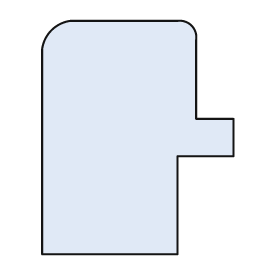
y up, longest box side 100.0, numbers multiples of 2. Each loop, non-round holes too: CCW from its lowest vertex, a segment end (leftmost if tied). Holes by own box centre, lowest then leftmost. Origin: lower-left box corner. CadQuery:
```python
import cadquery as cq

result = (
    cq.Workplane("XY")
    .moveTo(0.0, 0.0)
    .lineTo(58.0, 0.0)
    .lineTo(58.0, 42.0)
    .lineTo(82.0, 42.0)
    .lineTo(82.0, 58.0)
    .lineTo(66.0, 58.0)
    .lineTo(66.0, 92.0)
    .threePointArc((64.0, 98.0), (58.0, 100.0))
    .lineTo(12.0, 100.0)
    .threePointArc((4.0, 96.0), (0.0, 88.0))
    .close()
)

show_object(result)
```